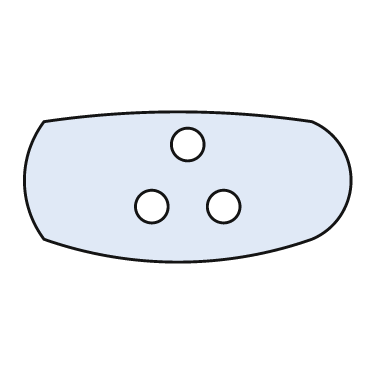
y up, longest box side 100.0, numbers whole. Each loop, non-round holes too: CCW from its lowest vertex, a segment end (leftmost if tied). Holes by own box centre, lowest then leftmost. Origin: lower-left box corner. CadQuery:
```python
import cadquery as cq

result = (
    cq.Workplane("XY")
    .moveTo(6.0, 7.0)
    .threePointArc((47.0, 0.0), (88.0, 7.0))
    .threePointArc((100.0, 25.0), (88.0, 43.0))
    .threePointArc((47.0, 46.0), (6.0, 43.0))
    .threePointArc((0.0, 25.0), (6.0, 7.0))
    .close()
    .moveTo(39.0, 17.0)
    .circle(5.0)
    .moveTo(61.0, 17.0)
    .circle(5.0)
    .moveTo(50.0, 36.0)
    .circle(5.0)
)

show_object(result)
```